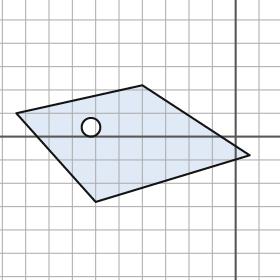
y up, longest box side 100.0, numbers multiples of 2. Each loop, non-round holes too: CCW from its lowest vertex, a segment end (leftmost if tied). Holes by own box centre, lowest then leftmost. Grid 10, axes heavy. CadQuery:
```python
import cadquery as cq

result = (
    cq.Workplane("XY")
    .moveTo(-60.0, -28.0)
    .lineTo(6.0, -8.0)
    .lineTo(-40.0, 22.0)
    .lineTo(-94.0, 10.0)
    .close()
    .moveTo(-62.0, 4.0)
    .circle(4.0)
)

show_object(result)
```